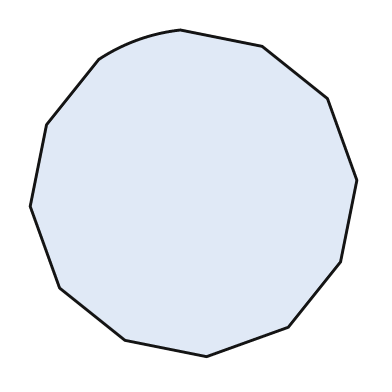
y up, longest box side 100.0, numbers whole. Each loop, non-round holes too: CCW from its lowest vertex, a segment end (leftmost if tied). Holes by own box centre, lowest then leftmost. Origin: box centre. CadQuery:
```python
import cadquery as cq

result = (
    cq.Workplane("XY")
    .moveTo(4.0, -50.0)
    .lineTo(29.0, -41.0)
    .lineTo(45.0, -21.0)
    .lineTo(50.0, 4.0)
    .lineTo(41.0, 29.0)
    .lineTo(21.0, 45.0)
    .lineTo(-4.0, 50.0)
    .threePointArc((-17.0, 47.0), (-29.0, 41.0))
    .lineTo(-45.0, 21.0)
    .lineTo(-50.0, -4.0)
    .lineTo(-41.0, -29.0)
    .lineTo(-21.0, -45.0)
    .close()
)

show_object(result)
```